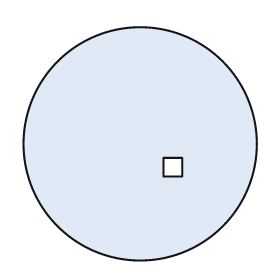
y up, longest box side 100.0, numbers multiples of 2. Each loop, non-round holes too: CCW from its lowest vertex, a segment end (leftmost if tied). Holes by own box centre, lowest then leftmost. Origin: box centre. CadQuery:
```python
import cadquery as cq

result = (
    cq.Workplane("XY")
    .moveTo(0.0, 0.0)
    .circle(50.0)
    .moveTo(10.0, -14.0)
    .lineTo(18.0, -14.0)
    .lineTo(18.0, -6.0)
    .lineTo(10.0, -6.0)
    .close()
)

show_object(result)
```